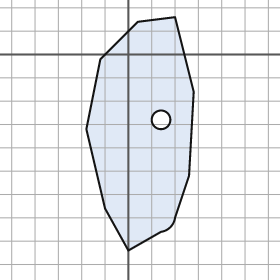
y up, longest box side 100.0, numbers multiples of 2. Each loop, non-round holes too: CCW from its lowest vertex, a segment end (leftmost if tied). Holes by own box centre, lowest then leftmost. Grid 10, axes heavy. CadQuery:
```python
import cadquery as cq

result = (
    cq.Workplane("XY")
    .moveTo(0.0, -84.0)
    .lineTo(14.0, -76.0)
    .threePointArc((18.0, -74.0), (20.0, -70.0))
    .lineTo(26.0, -52.0)
    .lineTo(28.0, -16.0)
    .lineTo(20.0, 16.0)
    .lineTo(4.0, 14.0)
    .lineTo(-12.0, -2.0)
    .lineTo(-18.0, -32.0)
    .lineTo(-10.0, -66.0)
    .close()
    .moveTo(14.0, -28.0)
    .circle(4.0)
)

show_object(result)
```